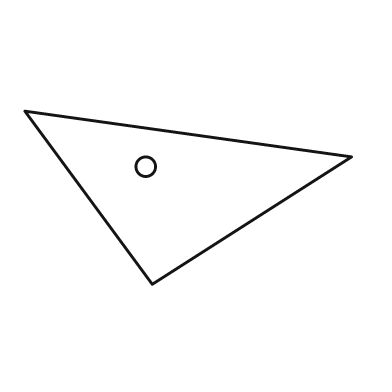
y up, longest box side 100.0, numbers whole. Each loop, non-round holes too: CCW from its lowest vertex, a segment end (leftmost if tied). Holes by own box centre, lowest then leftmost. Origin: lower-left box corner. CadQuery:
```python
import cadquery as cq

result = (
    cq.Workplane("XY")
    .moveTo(39.0, 0.0)
    .lineTo(100.0, 39.0)
    .lineTo(0.0, 53.0)
    .close()
    .moveTo(37.0, 36.0)
    .circle(3.0)
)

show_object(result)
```